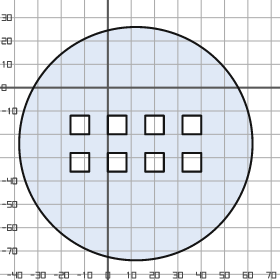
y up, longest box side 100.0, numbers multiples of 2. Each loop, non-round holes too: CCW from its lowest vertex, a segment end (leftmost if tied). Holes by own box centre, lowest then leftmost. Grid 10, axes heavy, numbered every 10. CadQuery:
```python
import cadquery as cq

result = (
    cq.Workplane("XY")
    .moveTo(12.0, -24.0)
    .circle(50.0)
    .moveTo(-16.0, -36.0)
    .lineTo(-8.0, -36.0)
    .lineTo(-8.0, -28.0)
    .lineTo(-16.0, -28.0)
    .close()
    .moveTo(0.0, -36.0)
    .lineTo(8.0, -36.0)
    .lineTo(8.0, -28.0)
    .lineTo(0.0, -28.0)
    .close()
    .moveTo(16.0, -36.0)
    .lineTo(24.0, -36.0)
    .lineTo(24.0, -28.0)
    .lineTo(16.0, -28.0)
    .close()
    .moveTo(32.0, -36.0)
    .lineTo(40.0, -36.0)
    .lineTo(40.0, -28.0)
    .lineTo(32.0, -28.0)
    .close()
    .moveTo(-16.0, -20.0)
    .lineTo(-8.0, -20.0)
    .lineTo(-8.0, -12.0)
    .lineTo(-16.0, -12.0)
    .close()
    .moveTo(0.0, -20.0)
    .lineTo(8.0, -20.0)
    .lineTo(8.0, -12.0)
    .lineTo(0.0, -12.0)
    .close()
    .moveTo(16.0, -20.0)
    .lineTo(24.0, -20.0)
    .lineTo(24.0, -12.0)
    .lineTo(16.0, -12.0)
    .close()
    .moveTo(32.0, -20.0)
    .lineTo(40.0, -20.0)
    .lineTo(40.0, -12.0)
    .lineTo(32.0, -12.0)
    .close()
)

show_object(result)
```